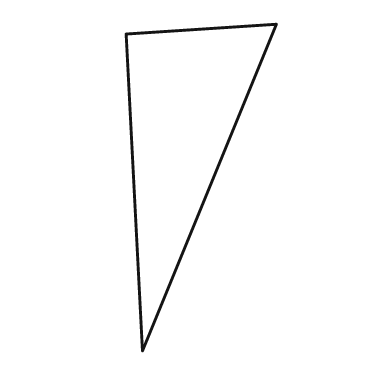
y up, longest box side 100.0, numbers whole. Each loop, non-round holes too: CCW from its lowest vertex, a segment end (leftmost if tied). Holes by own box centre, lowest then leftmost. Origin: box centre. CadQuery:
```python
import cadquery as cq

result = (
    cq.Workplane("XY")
    .moveTo(-18.0, -50.0)
    .lineTo(23.0, 50.0)
    .lineTo(-23.0, 47.0)
    .close()
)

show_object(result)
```